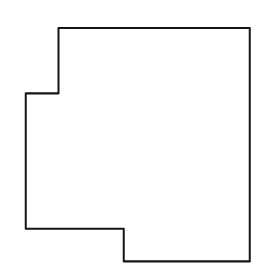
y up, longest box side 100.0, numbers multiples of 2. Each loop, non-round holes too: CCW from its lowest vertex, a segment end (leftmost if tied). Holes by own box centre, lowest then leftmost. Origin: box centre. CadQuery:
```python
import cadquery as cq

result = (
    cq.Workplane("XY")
    .moveTo(-6.0, -50.0)
    .lineTo(48.0, -50.0)
    .lineTo(48.0, 50.0)
    .lineTo(-34.0, 50.0)
    .lineTo(-34.0, 22.0)
    .lineTo(-48.0, 22.0)
    .lineTo(-48.0, -36.0)
    .lineTo(-6.0, -36.0)
    .close()
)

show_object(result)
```